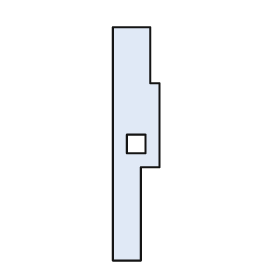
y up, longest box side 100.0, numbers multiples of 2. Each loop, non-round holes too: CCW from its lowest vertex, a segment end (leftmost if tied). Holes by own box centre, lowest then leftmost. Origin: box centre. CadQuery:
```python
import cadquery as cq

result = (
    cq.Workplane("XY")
    .moveTo(-10.0, -50.0)
    .lineTo(2.0, -50.0)
    .lineTo(2.0, -10.0)
    .lineTo(10.0, -10.0)
    .lineTo(10.0, 26.0)
    .lineTo(6.0, 26.0)
    .lineTo(6.0, 50.0)
    .lineTo(-10.0, 50.0)
    .close()
    .moveTo(-4.0, -4.0)
    .lineTo(4.0, -4.0)
    .lineTo(4.0, 4.0)
    .lineTo(-4.0, 4.0)
    .close()
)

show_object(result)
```